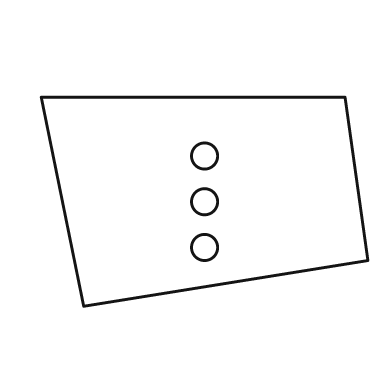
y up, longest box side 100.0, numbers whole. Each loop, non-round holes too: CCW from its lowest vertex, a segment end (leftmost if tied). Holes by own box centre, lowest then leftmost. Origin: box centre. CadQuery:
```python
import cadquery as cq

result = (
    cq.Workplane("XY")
    .moveTo(-37.0, -32.0)
    .lineTo(50.0, -18.0)
    .lineTo(43.0, 32.0)
    .lineTo(-50.0, 32.0)
    .close()
    .moveTo(0.0, -14.0)
    .circle(4.0)
    .moveTo(0.0, 0.0)
    .circle(4.0)
    .moveTo(0.0, 14.0)
    .circle(4.0)
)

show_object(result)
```